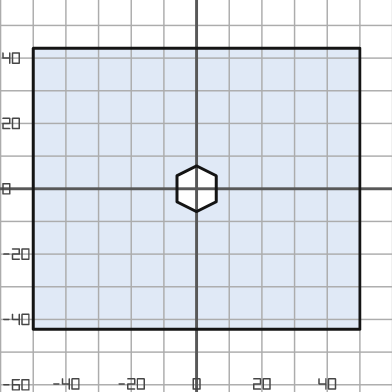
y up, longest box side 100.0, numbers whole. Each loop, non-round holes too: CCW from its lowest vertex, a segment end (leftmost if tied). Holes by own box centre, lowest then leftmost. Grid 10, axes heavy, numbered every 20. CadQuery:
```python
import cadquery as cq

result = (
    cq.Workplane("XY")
    .moveTo(-50.0, -43.0)
    .lineTo(50.0, -43.0)
    .lineTo(50.0, 43.0)
    .lineTo(-50.0, 43.0)
    .close()
    .moveTo(0.0, -7.0)
    .lineTo(6.0, -4.0)
    .lineTo(6.0, 4.0)
    .lineTo(0.0, 7.0)
    .lineTo(-6.0, 4.0)
    .lineTo(-6.0, -4.0)
    .close()
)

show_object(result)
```